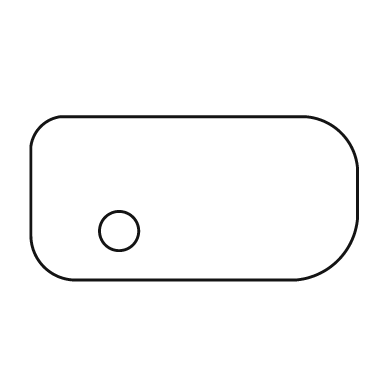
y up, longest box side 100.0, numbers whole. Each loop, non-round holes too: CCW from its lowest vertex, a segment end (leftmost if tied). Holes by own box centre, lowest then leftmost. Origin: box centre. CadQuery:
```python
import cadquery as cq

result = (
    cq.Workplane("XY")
    .moveTo(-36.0, -25.0)
    .lineTo(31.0, -25.0)
    .threePointArc((44.0, -19.0), (50.0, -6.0))
    .lineTo(50.0, 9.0)
    .threePointArc((45.0, 20.0), (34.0, 25.0))
    .lineTo(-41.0, 25.0)
    .threePointArc((-47.0, 22.0), (-50.0, 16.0))
    .lineTo(-50.0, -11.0)
    .threePointArc((-46.0, -21.0), (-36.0, -25.0))
    .close()
    .moveTo(-23.0, -10.0)
    .circle(6.0)
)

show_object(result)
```